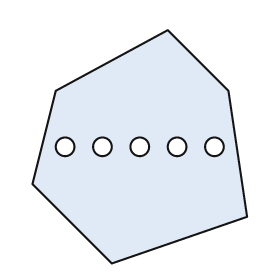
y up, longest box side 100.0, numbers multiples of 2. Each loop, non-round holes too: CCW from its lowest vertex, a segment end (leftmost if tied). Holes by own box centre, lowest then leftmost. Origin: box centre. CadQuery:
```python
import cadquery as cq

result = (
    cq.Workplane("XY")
    .moveTo(-12.0, -50.0)
    .lineTo(46.0, -30.0)
    .lineTo(38.0, 24.0)
    .lineTo(12.0, 50.0)
    .lineTo(-36.0, 24.0)
    .lineTo(-46.0, -16.0)
    .close()
    .moveTo(-32.0, 0.0)
    .circle(4.0)
    .moveTo(-16.0, 0.0)
    .circle(4.0)
    .moveTo(0.0, 0.0)
    .circle(4.0)
    .moveTo(16.0, 0.0)
    .circle(4.0)
    .moveTo(32.0, 0.0)
    .circle(4.0)
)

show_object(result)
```